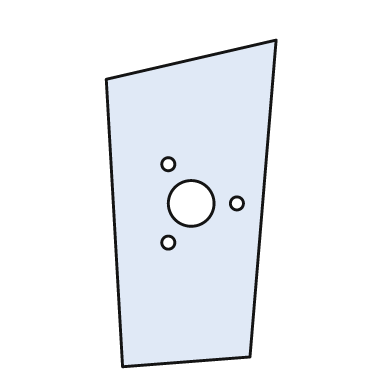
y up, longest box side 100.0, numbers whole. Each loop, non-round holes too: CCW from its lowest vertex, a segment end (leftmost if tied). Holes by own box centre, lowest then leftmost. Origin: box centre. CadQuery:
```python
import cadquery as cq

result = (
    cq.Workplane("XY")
    .moveTo(-21.0, -50.0)
    .lineTo(18.0, -47.0)
    .lineTo(26.0, 50.0)
    .lineTo(-26.0, 38.0)
    .close()
    .moveTo(-7.0, -12.0)
    .circle(2.0)
    .moveTo(0.0, 0.0)
    .circle(7.0)
    .moveTo(14.0, 0.0)
    .circle(2.0)
    .moveTo(-7.0, 12.0)
    .circle(2.0)
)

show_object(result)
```